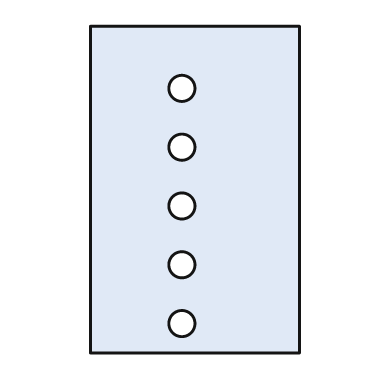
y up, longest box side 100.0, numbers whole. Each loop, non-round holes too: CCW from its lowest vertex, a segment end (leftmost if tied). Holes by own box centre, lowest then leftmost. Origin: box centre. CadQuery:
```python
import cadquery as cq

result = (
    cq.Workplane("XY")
    .moveTo(-32.0, -50.0)
    .lineTo(32.0, -50.0)
    .lineTo(32.0, 50.0)
    .lineTo(-32.0, 50.0)
    .close()
    .moveTo(-4.0, -41.0)
    .circle(4.0)
    .moveTo(-4.0, -23.0)
    .circle(4.0)
    .moveTo(-4.0, -5.0)
    .circle(4.0)
    .moveTo(-4.0, 13.0)
    .circle(4.0)
    .moveTo(-4.0, 31.0)
    .circle(4.0)
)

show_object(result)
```